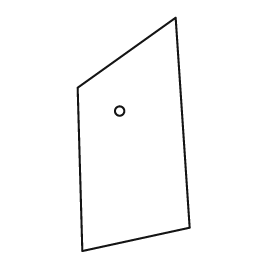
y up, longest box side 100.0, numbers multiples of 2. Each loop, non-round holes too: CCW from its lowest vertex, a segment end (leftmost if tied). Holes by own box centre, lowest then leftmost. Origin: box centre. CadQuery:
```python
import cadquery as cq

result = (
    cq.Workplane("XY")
    .moveTo(-22.0, -50.0)
    .lineTo(24.0, -40.0)
    .lineTo(18.0, 50.0)
    .lineTo(-24.0, 20.0)
    .close()
    .moveTo(-6.0, 10.0)
    .circle(2.0)
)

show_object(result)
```